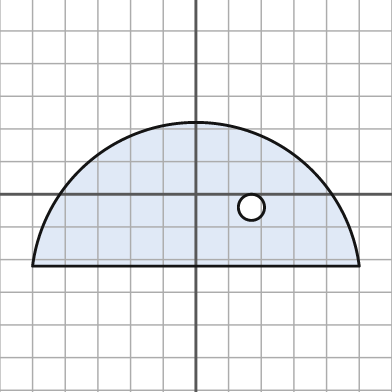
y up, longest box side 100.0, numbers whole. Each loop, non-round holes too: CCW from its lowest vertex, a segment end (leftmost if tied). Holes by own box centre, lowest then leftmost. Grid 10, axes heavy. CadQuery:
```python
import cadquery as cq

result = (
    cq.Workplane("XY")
    .moveTo(-50.0, -22.0)
    .lineTo(50.0, -22.0)
    .threePointArc((0.0, 22.0), (-50.0, -22.0))
    .close()
    .moveTo(17.0, -4.0)
    .circle(4.0)
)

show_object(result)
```